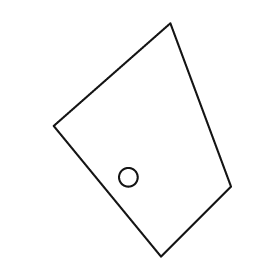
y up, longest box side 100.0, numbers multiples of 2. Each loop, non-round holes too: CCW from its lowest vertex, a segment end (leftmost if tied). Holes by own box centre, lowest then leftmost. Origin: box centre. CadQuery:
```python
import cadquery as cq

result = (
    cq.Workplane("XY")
    .moveTo(8.0, -50.0)
    .lineTo(38.0, -20.0)
    .lineTo(12.0, 50.0)
    .lineTo(-38.0, 6.0)
    .close()
    .moveTo(-6.0, -16.0)
    .circle(4.0)
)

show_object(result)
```